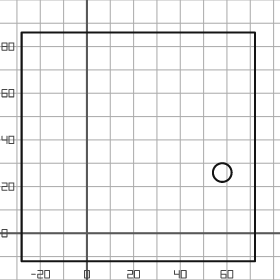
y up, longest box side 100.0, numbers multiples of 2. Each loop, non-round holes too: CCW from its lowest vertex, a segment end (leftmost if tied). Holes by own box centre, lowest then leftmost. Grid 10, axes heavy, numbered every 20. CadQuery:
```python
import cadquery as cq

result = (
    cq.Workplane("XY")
    .moveTo(-28.0, -12.0)
    .lineTo(72.0, -12.0)
    .lineTo(72.0, 86.0)
    .lineTo(-28.0, 86.0)
    .close()
    .moveTo(58.0, 26.0)
    .circle(4.0)
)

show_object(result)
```